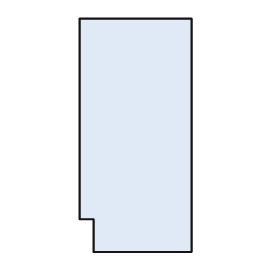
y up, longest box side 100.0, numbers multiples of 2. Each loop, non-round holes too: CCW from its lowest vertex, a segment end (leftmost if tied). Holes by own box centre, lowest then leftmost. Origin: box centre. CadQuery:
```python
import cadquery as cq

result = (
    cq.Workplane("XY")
    .moveTo(-18.0, -50.0)
    .lineTo(24.0, -50.0)
    .lineTo(24.0, 50.0)
    .lineTo(-24.0, 50.0)
    .lineTo(-24.0, -36.0)
    .lineTo(-18.0, -36.0)
    .close()
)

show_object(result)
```